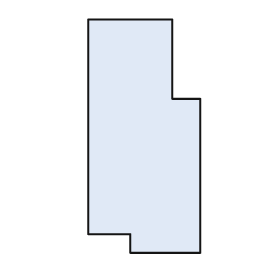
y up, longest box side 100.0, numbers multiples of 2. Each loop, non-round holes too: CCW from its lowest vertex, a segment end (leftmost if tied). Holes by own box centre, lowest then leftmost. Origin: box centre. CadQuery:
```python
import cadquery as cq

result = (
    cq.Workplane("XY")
    .moveTo(-6.0, -50.0)
    .lineTo(24.0, -50.0)
    .lineTo(24.0, 16.0)
    .lineTo(12.0, 16.0)
    .lineTo(12.0, 50.0)
    .lineTo(-24.0, 50.0)
    .lineTo(-24.0, -42.0)
    .lineTo(-6.0, -42.0)
    .close()
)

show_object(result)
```